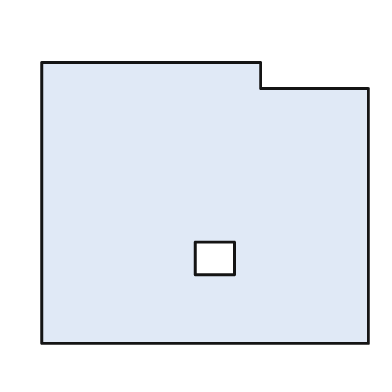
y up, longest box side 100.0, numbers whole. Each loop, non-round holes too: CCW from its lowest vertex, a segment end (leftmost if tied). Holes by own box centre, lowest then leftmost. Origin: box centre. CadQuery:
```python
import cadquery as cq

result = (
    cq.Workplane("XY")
    .moveTo(-50.0, -43.0)
    .lineTo(50.0, -43.0)
    .lineTo(50.0, 35.0)
    .lineTo(17.0, 35.0)
    .lineTo(17.0, 43.0)
    .lineTo(-50.0, 43.0)
    .close()
    .moveTo(-3.0, -22.0)
    .lineTo(9.0, -22.0)
    .lineTo(9.0, -12.0)
    .lineTo(-3.0, -12.0)
    .close()
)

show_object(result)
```